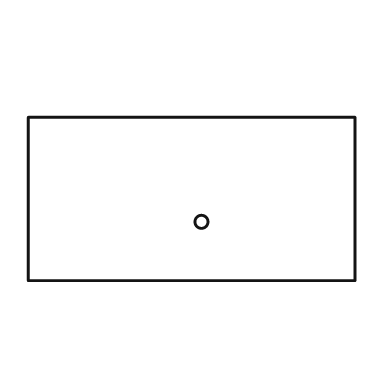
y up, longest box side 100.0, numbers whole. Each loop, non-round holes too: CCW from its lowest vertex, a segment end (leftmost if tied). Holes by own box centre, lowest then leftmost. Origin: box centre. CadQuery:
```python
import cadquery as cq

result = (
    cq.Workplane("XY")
    .moveTo(-50.0, -25.0)
    .lineTo(50.0, -25.0)
    .lineTo(50.0, 25.0)
    .lineTo(-50.0, 25.0)
    .close()
    .moveTo(3.0, -7.0)
    .circle(2.0)
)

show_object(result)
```